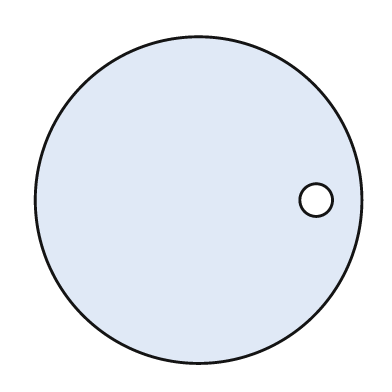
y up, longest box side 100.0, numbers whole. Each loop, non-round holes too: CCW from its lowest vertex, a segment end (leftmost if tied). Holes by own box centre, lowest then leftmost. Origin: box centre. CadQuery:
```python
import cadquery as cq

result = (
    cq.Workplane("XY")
    .moveTo(0.0, 0.0)
    .circle(50.0)
    .moveTo(36.0, 0.0)
    .circle(5.0)
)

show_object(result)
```